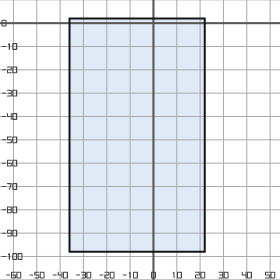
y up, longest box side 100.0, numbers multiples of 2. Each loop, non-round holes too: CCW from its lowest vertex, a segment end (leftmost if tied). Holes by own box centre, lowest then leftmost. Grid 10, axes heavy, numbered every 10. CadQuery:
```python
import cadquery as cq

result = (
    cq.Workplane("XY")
    .moveTo(-36.0, -98.0)
    .lineTo(22.0, -98.0)
    .lineTo(22.0, 2.0)
    .lineTo(-36.0, 2.0)
    .close()
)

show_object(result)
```